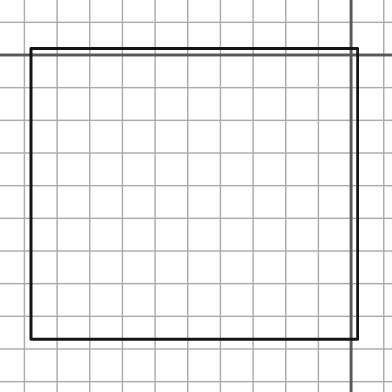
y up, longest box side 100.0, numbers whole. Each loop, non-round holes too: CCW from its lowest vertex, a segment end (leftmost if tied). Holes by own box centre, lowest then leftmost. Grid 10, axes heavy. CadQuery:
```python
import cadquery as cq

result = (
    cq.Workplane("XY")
    .moveTo(-98.0, -87.0)
    .lineTo(2.0, -87.0)
    .lineTo(2.0, 2.0)
    .lineTo(-98.0, 2.0)
    .close()
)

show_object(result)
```